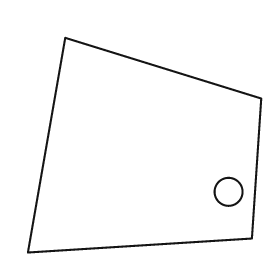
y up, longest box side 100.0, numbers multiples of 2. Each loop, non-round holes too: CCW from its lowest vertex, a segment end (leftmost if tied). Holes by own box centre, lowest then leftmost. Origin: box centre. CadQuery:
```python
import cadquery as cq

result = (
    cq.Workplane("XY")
    .moveTo(-50.0, -46.0)
    .lineTo(46.0, -40.0)
    .lineTo(50.0, 20.0)
    .lineTo(-34.0, 46.0)
    .close()
    .moveTo(36.0, -20.0)
    .circle(6.0)
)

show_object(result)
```